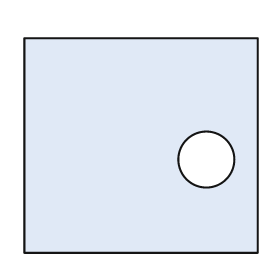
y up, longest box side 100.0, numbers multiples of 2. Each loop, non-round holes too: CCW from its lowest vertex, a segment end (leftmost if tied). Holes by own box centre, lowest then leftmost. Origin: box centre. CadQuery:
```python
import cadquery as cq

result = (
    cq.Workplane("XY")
    .moveTo(-50.0, -46.0)
    .lineTo(50.0, -46.0)
    .lineTo(50.0, 46.0)
    .lineTo(-50.0, 46.0)
    .close()
    .moveTo(28.0, -6.0)
    .circle(12.0)
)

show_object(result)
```